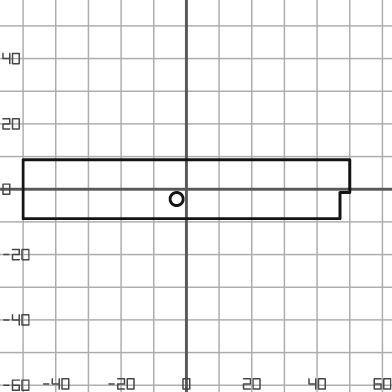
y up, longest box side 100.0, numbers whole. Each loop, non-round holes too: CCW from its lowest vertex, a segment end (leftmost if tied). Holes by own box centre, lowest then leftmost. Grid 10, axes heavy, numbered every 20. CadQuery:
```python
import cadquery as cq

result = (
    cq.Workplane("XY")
    .moveTo(-50.0, -9.0)
    .lineTo(47.0, -9.0)
    .lineTo(47.0, -1.0)
    .lineTo(50.0, -1.0)
    .lineTo(50.0, 9.0)
    .lineTo(-50.0, 9.0)
    .close()
    .moveTo(-3.0, -3.0)
    .circle(2.0)
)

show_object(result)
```